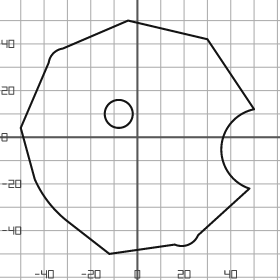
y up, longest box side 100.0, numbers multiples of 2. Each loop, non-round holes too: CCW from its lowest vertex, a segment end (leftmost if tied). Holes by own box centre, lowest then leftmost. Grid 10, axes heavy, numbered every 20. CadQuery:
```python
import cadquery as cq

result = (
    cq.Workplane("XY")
    .moveTo(-12.0, -50.0)
    .lineTo(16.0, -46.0)
    .threePointArc((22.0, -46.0), (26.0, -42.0))
    .lineTo(48.0, -22.0)
    .threePointArc((36.0, -4.0), (50.0, 12.0))
    .lineTo(30.0, 42.0)
    .lineTo(-4.0, 50.0)
    .lineTo(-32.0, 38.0)
    .threePointArc((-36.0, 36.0), (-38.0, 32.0))
    .lineTo(-50.0, 4.0)
    .lineTo(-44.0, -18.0)
    .threePointArc((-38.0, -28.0), (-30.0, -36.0))
    .close()
    .moveTo(-8.0, 10.0)
    .circle(6.0)
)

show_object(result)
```